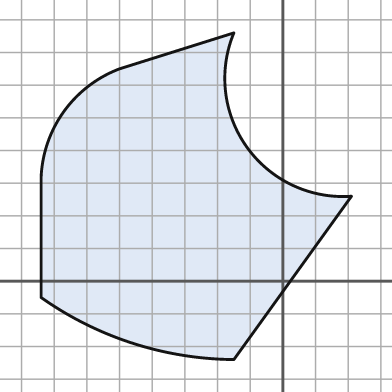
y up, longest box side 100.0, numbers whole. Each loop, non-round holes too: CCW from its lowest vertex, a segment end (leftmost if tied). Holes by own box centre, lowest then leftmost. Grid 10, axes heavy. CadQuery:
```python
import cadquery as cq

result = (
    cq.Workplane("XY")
    .moveTo(-15.0, -24.0)
    .lineTo(21.0, 26.0)
    .threePointArc((-11.0, 41.0), (-15.0, 76.0))
    .lineTo(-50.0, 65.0)
    .threePointArc((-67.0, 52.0), (-74.0, 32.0))
    .lineTo(-74.0, -5.0)
    .threePointArc((-46.0, -19.0), (-15.0, -24.0))
    .close()
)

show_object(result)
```